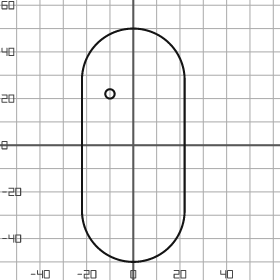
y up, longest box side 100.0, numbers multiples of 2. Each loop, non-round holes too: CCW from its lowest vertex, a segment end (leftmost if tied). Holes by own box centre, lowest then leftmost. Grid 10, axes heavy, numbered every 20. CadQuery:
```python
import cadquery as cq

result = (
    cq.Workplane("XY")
    .moveTo(-22.0, -28.0)
    .threePointArc((0.0, -50.0), (22.0, -28.0))
    .lineTo(22.0, 28.0)
    .threePointArc((0.0, 50.0), (-22.0, 28.0))
    .close()
    .moveTo(-10.0, 22.0)
    .circle(2.0)
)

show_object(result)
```